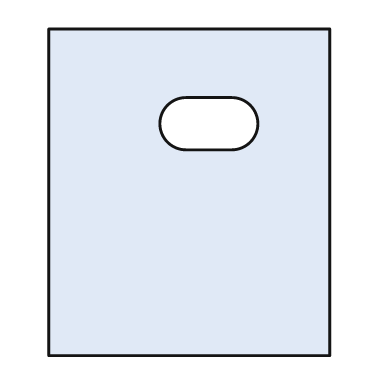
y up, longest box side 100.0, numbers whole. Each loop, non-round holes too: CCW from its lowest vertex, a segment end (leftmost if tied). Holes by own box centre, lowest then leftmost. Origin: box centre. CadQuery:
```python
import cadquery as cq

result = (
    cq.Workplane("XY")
    .moveTo(-43.0, -50.0)
    .lineTo(43.0, -50.0)
    .lineTo(43.0, 50.0)
    .lineTo(-43.0, 50.0)
    .close()
    .moveTo(-1.0, 13.0)
    .lineTo(13.0, 13.0)
    .threePointArc((21.0, 21.0), (13.0, 29.0))
    .lineTo(-1.0, 29.0)
    .threePointArc((-9.0, 21.0), (-1.0, 13.0))
    .close()
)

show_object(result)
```